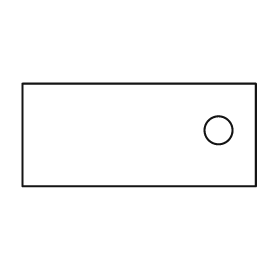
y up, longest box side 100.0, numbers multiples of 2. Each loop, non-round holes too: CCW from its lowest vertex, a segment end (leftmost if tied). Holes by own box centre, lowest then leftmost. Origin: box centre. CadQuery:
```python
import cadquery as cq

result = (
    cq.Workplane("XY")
    .moveTo(-50.0, -22.0)
    .lineTo(50.0, -22.0)
    .lineTo(50.0, 22.0)
    .lineTo(-50.0, 22.0)
    .close()
    .moveTo(34.0, 2.0)
    .circle(6.0)
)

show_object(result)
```